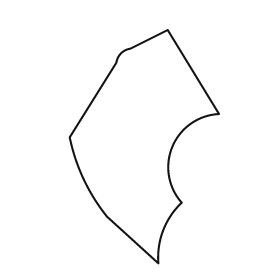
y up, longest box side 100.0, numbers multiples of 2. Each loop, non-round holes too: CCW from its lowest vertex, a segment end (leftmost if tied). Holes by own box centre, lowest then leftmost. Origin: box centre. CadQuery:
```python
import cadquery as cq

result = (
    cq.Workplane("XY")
    .moveTo(6.0, -50.0)
    .threePointArc((8.0, -36.0), (16.0, -24.0))
    .threePointArc((12.0, 0.0), (32.0, 14.0))
    .lineTo(10.0, 50.0)
    .lineTo(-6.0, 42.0)
    .threePointArc((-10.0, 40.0), (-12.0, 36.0))
    .lineTo(-32.0, 4.0)
    .threePointArc((-26.0, -14.0), (-16.0, -30.0))
    .close()
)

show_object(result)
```